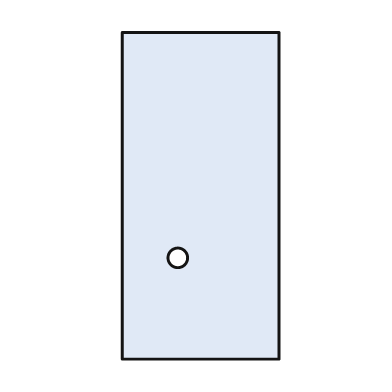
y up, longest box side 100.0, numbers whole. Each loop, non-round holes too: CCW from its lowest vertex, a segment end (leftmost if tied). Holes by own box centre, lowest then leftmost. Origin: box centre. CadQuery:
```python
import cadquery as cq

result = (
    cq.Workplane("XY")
    .moveTo(-24.0, -50.0)
    .lineTo(24.0, -50.0)
    .lineTo(24.0, 50.0)
    .lineTo(-24.0, 50.0)
    .close()
    .moveTo(-7.0, -19.0)
    .circle(3.0)
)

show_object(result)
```